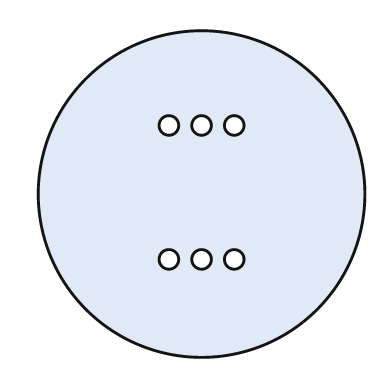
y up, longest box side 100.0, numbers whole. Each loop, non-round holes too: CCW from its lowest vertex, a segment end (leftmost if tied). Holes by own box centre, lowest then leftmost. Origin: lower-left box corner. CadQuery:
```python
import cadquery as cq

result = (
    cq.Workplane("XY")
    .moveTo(50.0, 50.0)
    .circle(50.0)
    .moveTo(40.0, 30.0)
    .circle(3.0)
    .moveTo(50.0, 30.0)
    .circle(3.0)
    .moveTo(60.0, 30.0)
    .circle(3.0)
    .moveTo(40.0, 71.0)
    .circle(3.0)
    .moveTo(50.0, 71.0)
    .circle(3.0)
    .moveTo(60.0, 71.0)
    .circle(3.0)
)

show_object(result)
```